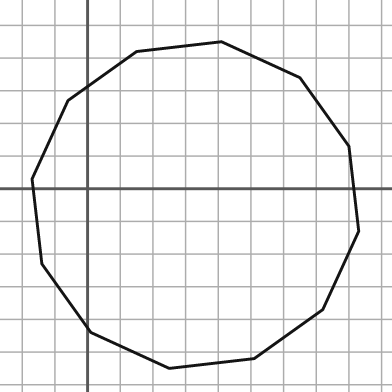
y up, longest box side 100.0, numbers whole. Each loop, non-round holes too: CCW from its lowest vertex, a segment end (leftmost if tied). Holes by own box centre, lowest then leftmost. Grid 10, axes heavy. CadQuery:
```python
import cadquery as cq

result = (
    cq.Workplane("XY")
    .moveTo(25.0, -55.0)
    .lineTo(51.0, -52.0)
    .lineTo(72.0, -37.0)
    .lineTo(83.0, -13.0)
    .lineTo(80.0, 13.0)
    .lineTo(65.0, 34.0)
    .lineTo(41.0, 45.0)
    .lineTo(15.0, 42.0)
    .lineTo(-6.0, 27.0)
    .lineTo(-17.0, 3.0)
    .lineTo(-14.0, -23.0)
    .lineTo(1.0, -44.0)
    .close()
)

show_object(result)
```